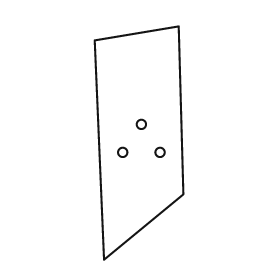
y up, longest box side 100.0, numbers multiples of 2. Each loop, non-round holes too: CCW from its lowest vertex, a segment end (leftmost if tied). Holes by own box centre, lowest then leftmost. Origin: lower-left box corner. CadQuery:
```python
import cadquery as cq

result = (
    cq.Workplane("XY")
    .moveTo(4.0, 0.0)
    .lineTo(38.0, 28.0)
    .lineTo(36.0, 100.0)
    .lineTo(0.0, 94.0)
    .close()
    .moveTo(12.0, 46.0)
    .circle(2.0)
    .moveTo(28.0, 46.0)
    .circle(2.0)
    .moveTo(20.0, 58.0)
    .circle(2.0)
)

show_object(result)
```